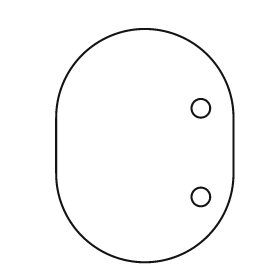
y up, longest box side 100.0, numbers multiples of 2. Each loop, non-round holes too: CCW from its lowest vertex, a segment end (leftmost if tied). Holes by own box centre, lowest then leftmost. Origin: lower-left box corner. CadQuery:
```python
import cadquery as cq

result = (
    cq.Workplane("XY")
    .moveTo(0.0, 38.0)
    .threePointArc((38.0, 0.0), (76.0, 38.0))
    .lineTo(76.0, 62.0)
    .threePointArc((38.0, 100.0), (0.0, 62.0))
    .close()
    .moveTo(62.0, 28.0)
    .circle(4.0)
    .moveTo(62.0, 66.0)
    .circle(4.0)
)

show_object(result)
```